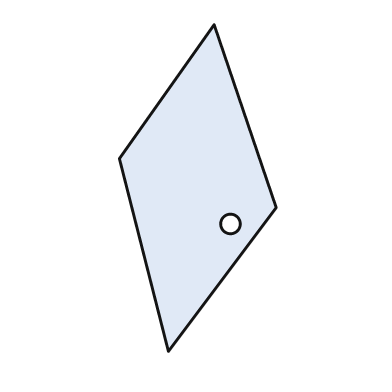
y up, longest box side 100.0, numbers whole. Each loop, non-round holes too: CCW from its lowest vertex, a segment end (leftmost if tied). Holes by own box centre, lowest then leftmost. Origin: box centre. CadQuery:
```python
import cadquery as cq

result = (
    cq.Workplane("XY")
    .moveTo(-9.0, -50.0)
    .lineTo(24.0, -6.0)
    .lineTo(5.0, 50.0)
    .lineTo(-24.0, 9.0)
    .close()
    .moveTo(10.0, -11.0)
    .circle(3.0)
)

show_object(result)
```